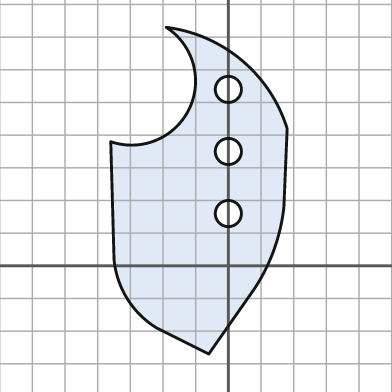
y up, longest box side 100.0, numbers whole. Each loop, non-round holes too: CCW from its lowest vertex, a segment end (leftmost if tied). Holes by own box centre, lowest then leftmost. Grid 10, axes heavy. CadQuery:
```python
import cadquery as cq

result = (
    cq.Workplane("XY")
    .moveTo(-6.0, -27.0)
    .lineTo(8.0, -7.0)
    .threePointArc((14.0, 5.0), (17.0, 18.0))
    .lineTo(18.0, 42.0)
    .threePointArc((4.0, 63.0), (-19.0, 73.0))
    .threePointArc((-12.0, 48.0), (-36.0, 38.0))
    .lineTo(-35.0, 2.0)
    .threePointArc((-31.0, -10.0), (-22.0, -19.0))
    .close()
    .moveTo(0.0, 16.0)
    .circle(4.0)
    .moveTo(0.0, 35.0)
    .circle(4.0)
    .moveTo(0.0, 54.0)
    .circle(4.0)
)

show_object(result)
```